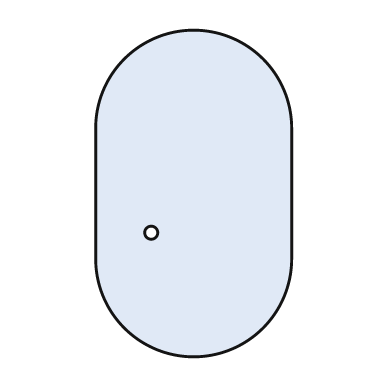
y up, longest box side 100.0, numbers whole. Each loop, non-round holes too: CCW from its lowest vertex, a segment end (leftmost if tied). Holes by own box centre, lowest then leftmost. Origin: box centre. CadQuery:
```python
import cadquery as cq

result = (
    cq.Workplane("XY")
    .moveTo(-30.0, -20.0)
    .threePointArc((0.0, -50.0), (30.0, -20.0))
    .lineTo(30.0, 20.0)
    .threePointArc((0.0, 50.0), (-30.0, 20.0))
    .close()
    .moveTo(-13.0, -12.0)
    .circle(2.0)
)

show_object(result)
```